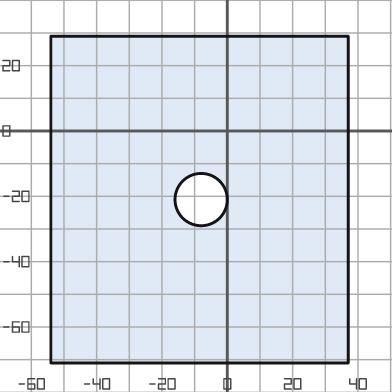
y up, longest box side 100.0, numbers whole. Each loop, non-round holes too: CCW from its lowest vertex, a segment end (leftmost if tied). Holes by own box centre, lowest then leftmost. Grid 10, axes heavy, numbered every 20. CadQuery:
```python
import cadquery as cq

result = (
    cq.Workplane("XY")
    .moveTo(-54.0, -71.0)
    .lineTo(37.0, -71.0)
    .lineTo(37.0, 29.0)
    .lineTo(-54.0, 29.0)
    .close()
    .moveTo(-8.0, -21.0)
    .circle(8.0)
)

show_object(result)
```